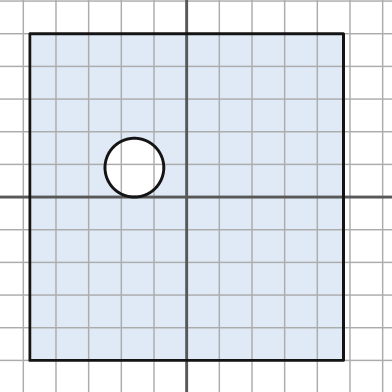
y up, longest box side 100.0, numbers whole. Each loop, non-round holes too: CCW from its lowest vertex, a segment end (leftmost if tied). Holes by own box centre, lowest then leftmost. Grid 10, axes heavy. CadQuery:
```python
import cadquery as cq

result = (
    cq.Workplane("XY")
    .moveTo(-48.0, -50.0)
    .lineTo(48.0, -50.0)
    .lineTo(48.0, 50.0)
    .lineTo(-48.0, 50.0)
    .close()
    .moveTo(-16.0, 9.0)
    .circle(9.0)
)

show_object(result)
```